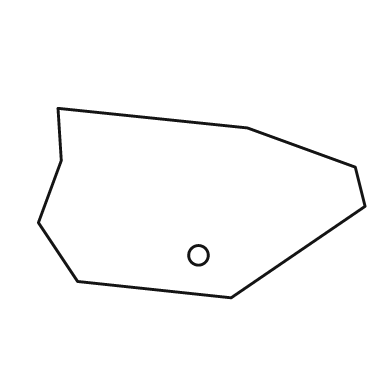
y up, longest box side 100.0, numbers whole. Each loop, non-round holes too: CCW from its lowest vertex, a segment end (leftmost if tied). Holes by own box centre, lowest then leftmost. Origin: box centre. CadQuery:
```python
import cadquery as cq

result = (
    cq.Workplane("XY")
    .moveTo(9.0, -29.0)
    .lineTo(50.0, -1.0)
    .lineTo(47.0, 11.0)
    .lineTo(14.0, 23.0)
    .lineTo(-44.0, 29.0)
    .lineTo(-43.0, 13.0)
    .lineTo(-50.0, -6.0)
    .lineTo(-38.0, -24.0)
    .close()
    .moveTo(-1.0, -16.0)
    .circle(3.0)
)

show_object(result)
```